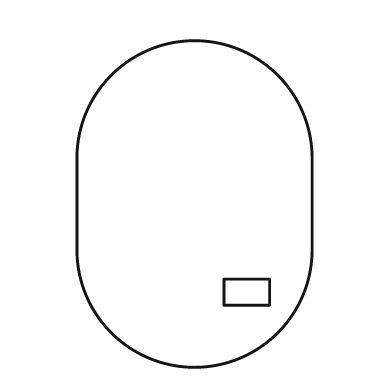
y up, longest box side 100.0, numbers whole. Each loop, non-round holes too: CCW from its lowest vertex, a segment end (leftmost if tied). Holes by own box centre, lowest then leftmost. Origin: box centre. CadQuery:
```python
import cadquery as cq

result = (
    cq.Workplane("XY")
    .moveTo(-36.0, -14.0)
    .threePointArc((0.0, -50.0), (36.0, -14.0))
    .lineTo(36.0, 14.0)
    .threePointArc((0.0, 50.0), (-36.0, 14.0))
    .close()
    .moveTo(9.0, -31.0)
    .lineTo(23.0, -31.0)
    .lineTo(23.0, -23.0)
    .lineTo(9.0, -23.0)
    .close()
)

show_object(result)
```